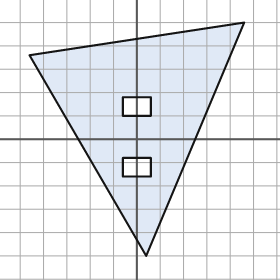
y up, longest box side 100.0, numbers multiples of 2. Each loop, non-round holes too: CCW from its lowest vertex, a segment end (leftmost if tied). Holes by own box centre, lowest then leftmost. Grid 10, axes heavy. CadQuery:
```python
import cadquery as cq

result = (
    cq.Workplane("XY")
    .moveTo(4.0, -50.0)
    .lineTo(46.0, 50.0)
    .lineTo(-46.0, 36.0)
    .close()
    .moveTo(-6.0, -16.0)
    .lineTo(6.0, -16.0)
    .lineTo(6.0, -8.0)
    .lineTo(-6.0, -8.0)
    .close()
    .moveTo(-6.0, 10.0)
    .lineTo(6.0, 10.0)
    .lineTo(6.0, 18.0)
    .lineTo(-6.0, 18.0)
    .close()
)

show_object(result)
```